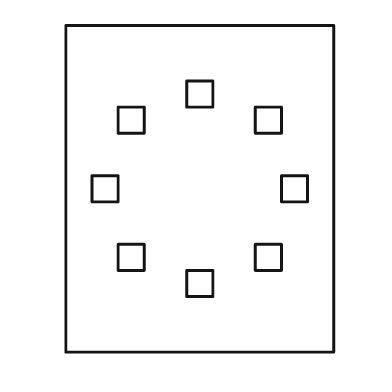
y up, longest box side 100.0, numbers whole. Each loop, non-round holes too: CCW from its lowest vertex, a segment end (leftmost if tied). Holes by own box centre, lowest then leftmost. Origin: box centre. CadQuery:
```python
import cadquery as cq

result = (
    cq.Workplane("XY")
    .moveTo(-41.0, -50.0)
    .lineTo(41.0, -50.0)
    .lineTo(41.0, 50.0)
    .lineTo(-41.0, 50.0)
    .close()
    .moveTo(-4.0, -33.0)
    .lineTo(4.0, -33.0)
    .lineTo(4.0, -25.0)
    .lineTo(-4.0, -25.0)
    .close()
    .moveTo(-25.0, -25.0)
    .lineTo(-17.0, -25.0)
    .lineTo(-17.0, -17.0)
    .lineTo(-25.0, -17.0)
    .close()
    .moveTo(17.0, -25.0)
    .lineTo(25.0, -25.0)
    .lineTo(25.0, -17.0)
    .lineTo(17.0, -17.0)
    .close()
    .moveTo(-33.0, -4.0)
    .lineTo(-25.0, -4.0)
    .lineTo(-25.0, 4.0)
    .lineTo(-33.0, 4.0)
    .close()
    .moveTo(25.0, -4.0)
    .lineTo(33.0, -4.0)
    .lineTo(33.0, 4.0)
    .lineTo(25.0, 4.0)
    .close()
    .moveTo(-25.0, 17.0)
    .lineTo(-17.0, 17.0)
    .lineTo(-17.0, 25.0)
    .lineTo(-25.0, 25.0)
    .close()
    .moveTo(17.0, 17.0)
    .lineTo(25.0, 17.0)
    .lineTo(25.0, 25.0)
    .lineTo(17.0, 25.0)
    .close()
    .moveTo(-4.0, 25.0)
    .lineTo(4.0, 25.0)
    .lineTo(4.0, 33.0)
    .lineTo(-4.0, 33.0)
    .close()
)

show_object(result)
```